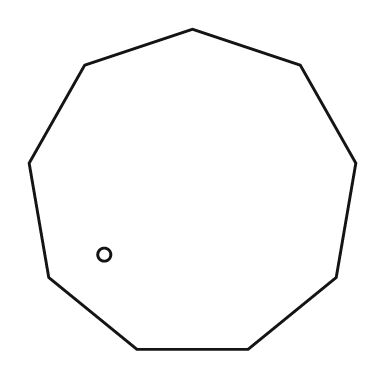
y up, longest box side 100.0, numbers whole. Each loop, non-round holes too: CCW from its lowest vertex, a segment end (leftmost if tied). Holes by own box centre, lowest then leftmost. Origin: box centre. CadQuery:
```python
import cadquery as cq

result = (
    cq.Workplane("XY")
    .moveTo(-17.0, -49.0)
    .lineTo(17.0, -49.0)
    .lineTo(44.0, -27.0)
    .lineTo(50.0, 8.0)
    .lineTo(33.0, 38.0)
    .lineTo(0.0, 49.0)
    .lineTo(-33.0, 38.0)
    .lineTo(-50.0, 8.0)
    .lineTo(-44.0, -27.0)
    .close()
    .moveTo(-27.0, -20.0)
    .circle(2.0)
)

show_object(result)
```